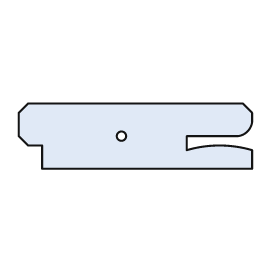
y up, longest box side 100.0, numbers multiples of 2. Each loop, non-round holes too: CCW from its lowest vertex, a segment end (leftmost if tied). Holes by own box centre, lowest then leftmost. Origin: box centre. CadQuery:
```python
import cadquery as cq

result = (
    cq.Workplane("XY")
    .moveTo(-40.0, -14.0)
    .lineTo(50.0, -14.0)
    .lineTo(50.0, -6.0)
    .threePointArc((36.0, -4.0), (22.0, -6.0))
    .lineTo(22.0, 0.0)
    .lineTo(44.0, 0.0)
    .threePointArc((48.0, 2.0), (50.0, 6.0))
    .lineTo(50.0, 10.0)
    .lineTo(46.0, 14.0)
    .lineTo(-46.0, 14.0)
    .lineTo(-50.0, 10.0)
    .lineTo(-50.0, 0.0)
    .lineTo(-46.0, -4.0)
    .lineTo(-40.0, -4.0)
    .close()
    .moveTo(-6.0, 0.0)
    .circle(2.0)
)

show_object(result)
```